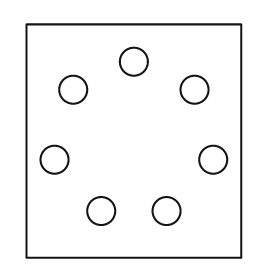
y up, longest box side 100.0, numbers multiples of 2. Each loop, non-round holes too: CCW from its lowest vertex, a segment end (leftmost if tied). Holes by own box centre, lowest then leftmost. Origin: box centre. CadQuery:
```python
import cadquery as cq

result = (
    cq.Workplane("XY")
    .moveTo(-46.0, -50.0)
    .lineTo(46.0, -50.0)
    .lineTo(46.0, 50.0)
    .lineTo(-46.0, 50.0)
    .close()
    .moveTo(-14.0, -30.0)
    .circle(6.0)
    .moveTo(14.0, -30.0)
    .circle(6.0)
    .moveTo(-34.0, -8.0)
    .circle(6.0)
    .moveTo(34.0, -8.0)
    .circle(6.0)
    .moveTo(-26.0, 22.0)
    .circle(6.0)
    .moveTo(26.0, 22.0)
    .circle(6.0)
    .moveTo(0.0, 34.0)
    .circle(6.0)
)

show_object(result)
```